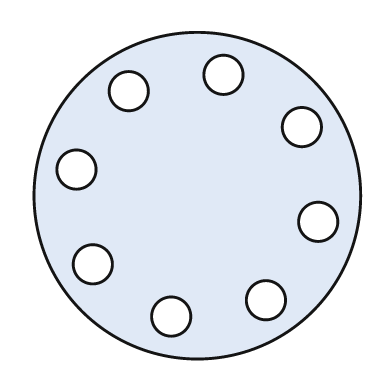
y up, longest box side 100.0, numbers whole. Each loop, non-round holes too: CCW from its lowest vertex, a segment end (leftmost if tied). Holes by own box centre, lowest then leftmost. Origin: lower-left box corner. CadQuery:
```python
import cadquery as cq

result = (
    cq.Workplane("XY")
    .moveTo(50.0, 50.0)
    .circle(50.0)
    .moveTo(42.0, 13.0)
    .circle(6.0)
    .moveTo(71.0, 18.0)
    .circle(6.0)
    .moveTo(18.0, 29.0)
    .circle(6.0)
    .moveTo(87.0, 42.0)
    .circle(6.0)
    .moveTo(13.0, 58.0)
    .circle(6.0)
    .moveTo(82.0, 71.0)
    .circle(6.0)
    .moveTo(29.0, 82.0)
    .circle(6.0)
    .moveTo(58.0, 87.0)
    .circle(6.0)
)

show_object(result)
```